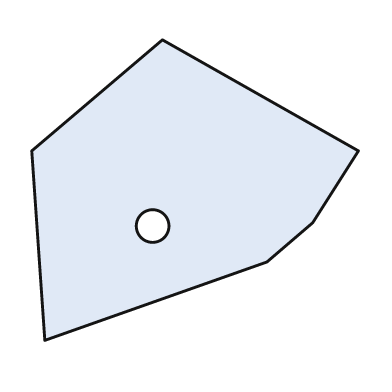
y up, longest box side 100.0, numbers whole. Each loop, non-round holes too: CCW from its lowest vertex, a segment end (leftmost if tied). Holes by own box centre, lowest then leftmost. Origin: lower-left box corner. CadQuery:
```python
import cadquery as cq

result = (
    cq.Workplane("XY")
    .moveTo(4.0, 0.0)
    .lineTo(72.0, 24.0)
    .lineTo(86.0, 36.0)
    .lineTo(100.0, 58.0)
    .lineTo(40.0, 92.0)
    .lineTo(0.0, 58.0)
    .close()
    .moveTo(37.0, 35.0)
    .circle(5.0)
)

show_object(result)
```